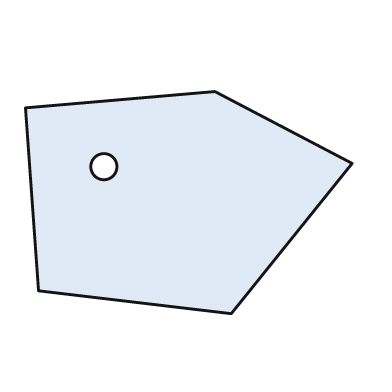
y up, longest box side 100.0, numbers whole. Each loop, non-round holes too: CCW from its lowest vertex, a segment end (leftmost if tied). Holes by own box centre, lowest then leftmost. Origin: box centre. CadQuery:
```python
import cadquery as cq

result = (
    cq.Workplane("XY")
    .moveTo(13.0, -34.0)
    .lineTo(50.0, 12.0)
    .lineTo(8.0, 34.0)
    .lineTo(-50.0, 29.0)
    .lineTo(-46.0, -27.0)
    .close()
    .moveTo(-26.0, 11.0)
    .circle(4.0)
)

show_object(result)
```